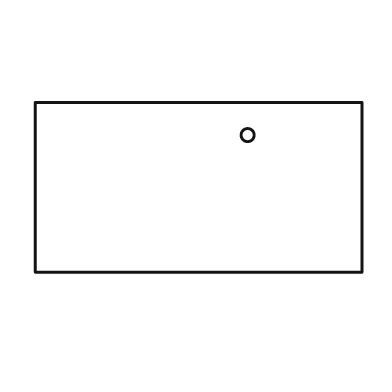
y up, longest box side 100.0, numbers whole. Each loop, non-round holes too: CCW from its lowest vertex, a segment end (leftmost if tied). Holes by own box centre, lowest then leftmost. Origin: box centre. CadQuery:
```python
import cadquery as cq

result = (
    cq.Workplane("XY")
    .moveTo(-50.0, -26.0)
    .lineTo(50.0, -26.0)
    .lineTo(50.0, 26.0)
    .lineTo(-50.0, 26.0)
    .close()
    .moveTo(15.0, 16.0)
    .circle(2.0)
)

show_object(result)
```